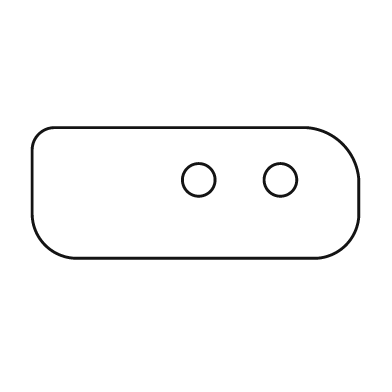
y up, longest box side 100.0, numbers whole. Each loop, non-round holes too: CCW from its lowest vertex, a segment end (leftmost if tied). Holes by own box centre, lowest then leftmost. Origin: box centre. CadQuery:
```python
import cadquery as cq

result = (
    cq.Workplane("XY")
    .moveTo(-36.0, -20.0)
    .lineTo(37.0, -20.0)
    .threePointArc((46.0, -16.0), (50.0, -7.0))
    .lineTo(50.0, 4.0)
    .threePointArc((45.0, 15.0), (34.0, 20.0))
    .lineTo(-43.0, 20.0)
    .threePointArc((-48.0, 18.0), (-50.0, 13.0))
    .lineTo(-50.0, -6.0)
    .threePointArc((-46.0, -16.0), (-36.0, -20.0))
    .close()
    .moveTo(1.0, 4.0)
    .circle(5.0)
    .moveTo(26.0, 4.0)
    .circle(5.0)
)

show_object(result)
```